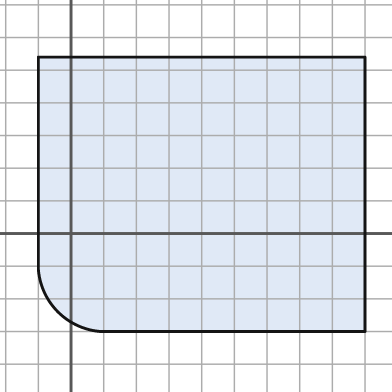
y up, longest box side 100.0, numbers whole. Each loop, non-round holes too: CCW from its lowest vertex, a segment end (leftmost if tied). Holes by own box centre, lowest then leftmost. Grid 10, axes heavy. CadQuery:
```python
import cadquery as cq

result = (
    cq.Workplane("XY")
    .moveTo(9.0, -30.0)
    .lineTo(90.0, -30.0)
    .lineTo(90.0, 54.0)
    .lineTo(-10.0, 54.0)
    .lineTo(-10.0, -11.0)
    .threePointArc((-4.0, -24.0), (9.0, -30.0))
    .close()
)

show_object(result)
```